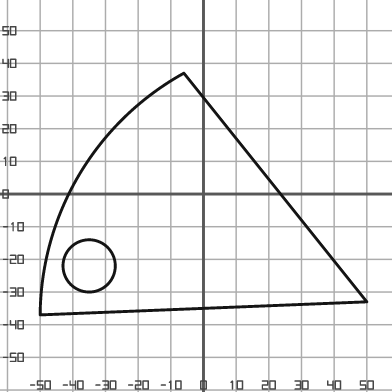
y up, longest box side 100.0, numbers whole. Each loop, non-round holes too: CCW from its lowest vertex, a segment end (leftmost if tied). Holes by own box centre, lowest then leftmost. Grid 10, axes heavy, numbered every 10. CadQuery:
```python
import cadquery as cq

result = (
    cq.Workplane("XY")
    .moveTo(-50.0, -37.0)
    .lineTo(50.0, -33.0)
    .lineTo(-6.0, 37.0)
    .threePointArc((-38.0, 6.0), (-50.0, -37.0))
    .close()
    .moveTo(-35.0, -22.0)
    .circle(8.0)
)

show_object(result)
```